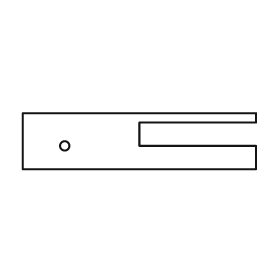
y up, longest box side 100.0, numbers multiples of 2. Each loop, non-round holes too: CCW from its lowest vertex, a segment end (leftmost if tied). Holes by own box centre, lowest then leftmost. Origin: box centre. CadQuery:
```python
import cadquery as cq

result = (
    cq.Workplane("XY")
    .moveTo(-50.0, -12.0)
    .lineTo(50.0, -12.0)
    .lineTo(50.0, -2.0)
    .lineTo(0.0, -2.0)
    .lineTo(0.0, 8.0)
    .lineTo(50.0, 8.0)
    .lineTo(50.0, 12.0)
    .lineTo(-50.0, 12.0)
    .close()
    .moveTo(-32.0, -2.0)
    .circle(2.0)
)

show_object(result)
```